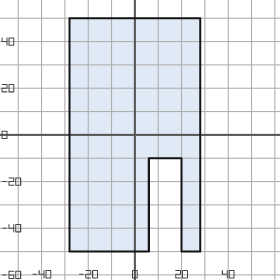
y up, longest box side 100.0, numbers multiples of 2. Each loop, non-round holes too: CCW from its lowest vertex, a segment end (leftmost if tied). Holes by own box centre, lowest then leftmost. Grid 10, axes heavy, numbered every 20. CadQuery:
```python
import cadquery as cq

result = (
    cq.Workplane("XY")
    .moveTo(-28.0, -50.0)
    .lineTo(6.0, -50.0)
    .lineTo(6.0, -10.0)
    .lineTo(20.0, -10.0)
    .lineTo(20.0, -50.0)
    .lineTo(28.0, -50.0)
    .lineTo(28.0, 50.0)
    .lineTo(-28.0, 50.0)
    .close()
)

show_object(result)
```